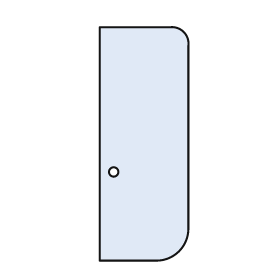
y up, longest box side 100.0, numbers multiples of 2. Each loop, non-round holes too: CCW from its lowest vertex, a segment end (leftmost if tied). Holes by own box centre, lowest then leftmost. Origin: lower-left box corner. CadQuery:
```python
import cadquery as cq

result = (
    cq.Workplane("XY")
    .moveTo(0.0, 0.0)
    .lineTo(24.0, 0.0)
    .threePointArc((34.0, 4.0), (38.0, 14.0))
    .lineTo(38.0, 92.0)
    .threePointArc((36.0, 98.0), (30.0, 100.0))
    .lineTo(0.0, 100.0)
    .close()
    .moveTo(6.0, 38.0)
    .circle(2.0)
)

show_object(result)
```